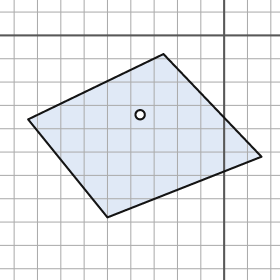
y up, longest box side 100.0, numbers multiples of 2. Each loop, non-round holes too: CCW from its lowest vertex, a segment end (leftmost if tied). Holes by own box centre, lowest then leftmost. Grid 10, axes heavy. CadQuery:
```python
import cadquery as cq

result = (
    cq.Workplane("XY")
    .moveTo(-50.0, -78.0)
    .lineTo(16.0, -52.0)
    .lineTo(-26.0, -8.0)
    .lineTo(-84.0, -36.0)
    .close()
    .moveTo(-36.0, -34.0)
    .circle(2.0)
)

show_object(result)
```